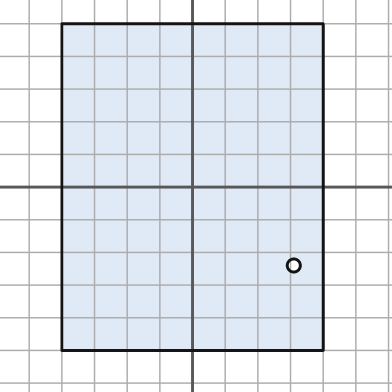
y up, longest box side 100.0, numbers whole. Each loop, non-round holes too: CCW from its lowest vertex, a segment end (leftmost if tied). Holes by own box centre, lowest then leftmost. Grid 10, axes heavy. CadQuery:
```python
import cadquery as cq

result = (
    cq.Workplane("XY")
    .moveTo(-40.0, -50.0)
    .lineTo(40.0, -50.0)
    .lineTo(40.0, 50.0)
    .lineTo(-40.0, 50.0)
    .close()
    .moveTo(31.0, -24.0)
    .circle(2.0)
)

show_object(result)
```